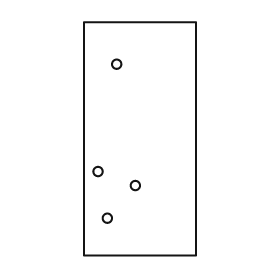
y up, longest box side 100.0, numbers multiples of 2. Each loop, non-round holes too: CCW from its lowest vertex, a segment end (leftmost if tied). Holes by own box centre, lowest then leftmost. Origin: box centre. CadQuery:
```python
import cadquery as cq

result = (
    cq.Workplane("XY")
    .moveTo(-24.0, -50.0)
    .lineTo(24.0, -50.0)
    .lineTo(24.0, 50.0)
    .lineTo(-24.0, 50.0)
    .close()
    .moveTo(-14.0, -34.0)
    .circle(2.0)
    .moveTo(-2.0, -20.0)
    .circle(2.0)
    .moveTo(-18.0, -14.0)
    .circle(2.0)
    .moveTo(-10.0, 32.0)
    .circle(2.0)
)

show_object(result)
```